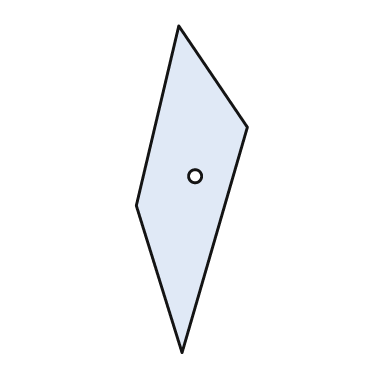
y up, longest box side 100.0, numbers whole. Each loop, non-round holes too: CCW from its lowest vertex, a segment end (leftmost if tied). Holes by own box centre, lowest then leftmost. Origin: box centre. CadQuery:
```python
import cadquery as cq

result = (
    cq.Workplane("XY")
    .moveTo(-3.0, -50.0)
    .lineTo(17.0, 19.0)
    .lineTo(-4.0, 50.0)
    .lineTo(-17.0, -5.0)
    .close()
    .moveTo(1.0, 4.0)
    .circle(2.0)
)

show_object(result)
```